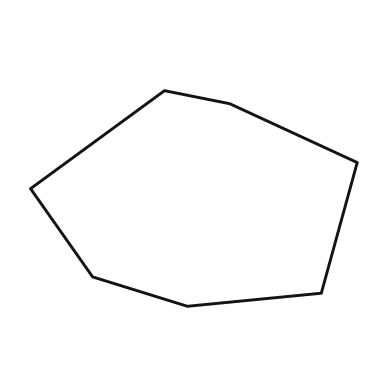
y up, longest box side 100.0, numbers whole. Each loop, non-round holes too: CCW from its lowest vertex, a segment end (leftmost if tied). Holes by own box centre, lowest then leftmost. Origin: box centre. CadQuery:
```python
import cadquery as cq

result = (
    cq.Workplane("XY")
    .moveTo(-2.0, -33.0)
    .lineTo(39.0, -29.0)
    .lineTo(50.0, 11.0)
    .lineTo(11.0, 29.0)
    .lineTo(-9.0, 33.0)
    .lineTo(-50.0, 3.0)
    .lineTo(-31.0, -24.0)
    .close()
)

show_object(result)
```